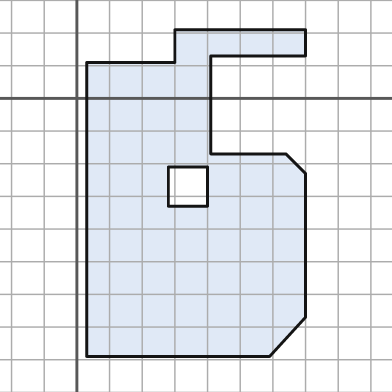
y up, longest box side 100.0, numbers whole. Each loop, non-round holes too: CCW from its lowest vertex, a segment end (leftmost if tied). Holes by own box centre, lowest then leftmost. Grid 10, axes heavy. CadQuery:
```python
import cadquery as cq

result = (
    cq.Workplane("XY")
    .moveTo(3.0, -79.0)
    .lineTo(59.0, -79.0)
    .lineTo(70.0, -67.0)
    .lineTo(70.0, -23.0)
    .lineTo(64.0, -17.0)
    .lineTo(41.0, -17.0)
    .lineTo(41.0, 13.0)
    .lineTo(70.0, 13.0)
    .lineTo(70.0, 21.0)
    .lineTo(30.0, 21.0)
    .lineTo(30.0, 11.0)
    .lineTo(3.0, 11.0)
    .close()
    .moveTo(28.0, -33.0)
    .lineTo(40.0, -33.0)
    .lineTo(40.0, -21.0)
    .lineTo(28.0, -21.0)
    .close()
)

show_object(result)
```